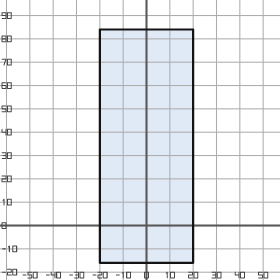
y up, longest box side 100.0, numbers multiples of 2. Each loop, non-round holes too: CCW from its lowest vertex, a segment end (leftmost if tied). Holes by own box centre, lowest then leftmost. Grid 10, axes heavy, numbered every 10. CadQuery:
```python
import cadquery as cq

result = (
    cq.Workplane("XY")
    .moveTo(-20.0, -16.0)
    .lineTo(20.0, -16.0)
    .lineTo(20.0, 84.0)
    .lineTo(-20.0, 84.0)
    .close()
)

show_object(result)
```